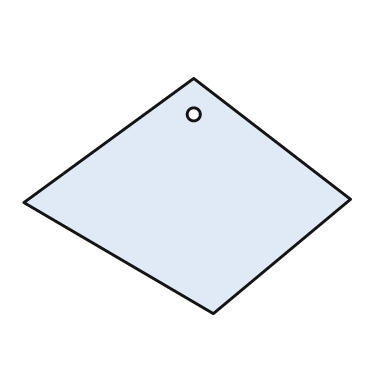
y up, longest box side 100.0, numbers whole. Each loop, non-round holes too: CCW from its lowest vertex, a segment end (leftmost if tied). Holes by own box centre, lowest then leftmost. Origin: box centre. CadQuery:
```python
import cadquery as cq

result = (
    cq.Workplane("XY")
    .moveTo(8.0, -36.0)
    .lineTo(50.0, -1.0)
    .lineTo(2.0, 36.0)
    .lineTo(-50.0, -2.0)
    .close()
    .moveTo(2.0, 25.0)
    .circle(2.0)
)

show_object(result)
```